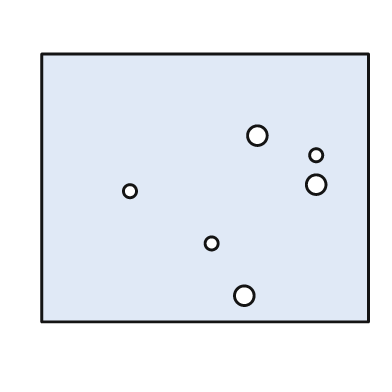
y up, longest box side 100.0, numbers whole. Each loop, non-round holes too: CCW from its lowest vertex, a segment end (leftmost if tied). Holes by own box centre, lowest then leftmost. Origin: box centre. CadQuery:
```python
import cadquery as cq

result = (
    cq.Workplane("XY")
    .moveTo(-50.0, -41.0)
    .lineTo(50.0, -41.0)
    .lineTo(50.0, 41.0)
    .lineTo(-50.0, 41.0)
    .close()
    .moveTo(12.0, -33.0)
    .circle(3.0)
    .moveTo(2.0, -17.0)
    .circle(2.0)
    .moveTo(-23.0, -1.0)
    .circle(2.0)
    .moveTo(34.0, 1.0)
    .circle(3.0)
    .moveTo(34.0, 10.0)
    .circle(2.0)
    .moveTo(16.0, 16.0)
    .circle(3.0)
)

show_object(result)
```